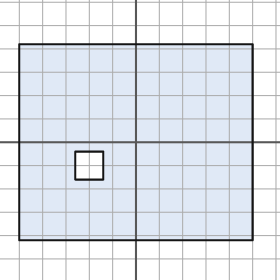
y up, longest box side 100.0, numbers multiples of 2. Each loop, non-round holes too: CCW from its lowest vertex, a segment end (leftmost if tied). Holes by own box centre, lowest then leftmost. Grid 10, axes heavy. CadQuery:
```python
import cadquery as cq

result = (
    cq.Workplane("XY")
    .moveTo(-50.0, -42.0)
    .lineTo(50.0, -42.0)
    .lineTo(50.0, 42.0)
    .lineTo(-50.0, 42.0)
    .close()
    .moveTo(-26.0, -16.0)
    .lineTo(-14.0, -16.0)
    .lineTo(-14.0, -4.0)
    .lineTo(-26.0, -4.0)
    .close()
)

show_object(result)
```